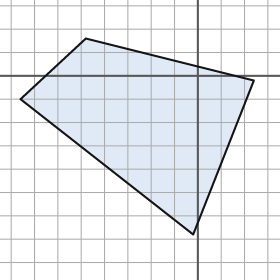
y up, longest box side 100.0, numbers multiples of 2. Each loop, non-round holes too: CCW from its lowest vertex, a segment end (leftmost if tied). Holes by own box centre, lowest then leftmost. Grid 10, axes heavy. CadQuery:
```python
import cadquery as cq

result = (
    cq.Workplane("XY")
    .moveTo(-2.0, -68.0)
    .lineTo(24.0, -2.0)
    .lineTo(-48.0, 16.0)
    .lineTo(-76.0, -10.0)
    .close()
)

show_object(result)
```